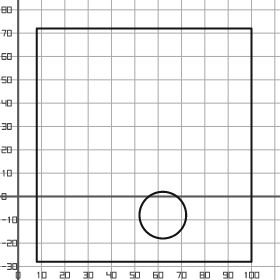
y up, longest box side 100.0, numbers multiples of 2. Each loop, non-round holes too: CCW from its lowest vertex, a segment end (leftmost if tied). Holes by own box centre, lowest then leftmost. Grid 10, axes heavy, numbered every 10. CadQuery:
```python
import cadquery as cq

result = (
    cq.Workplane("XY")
    .moveTo(8.0, -28.0)
    .lineTo(100.0, -28.0)
    .lineTo(100.0, 72.0)
    .lineTo(8.0, 72.0)
    .close()
    .moveTo(62.0, -8.0)
    .circle(10.0)
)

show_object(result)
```